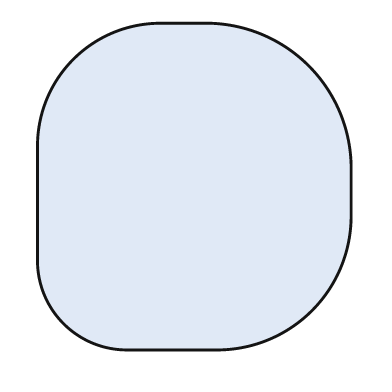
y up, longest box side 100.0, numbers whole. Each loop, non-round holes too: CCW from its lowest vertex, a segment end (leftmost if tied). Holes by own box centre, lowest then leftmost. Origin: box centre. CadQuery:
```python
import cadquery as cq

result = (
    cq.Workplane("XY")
    .moveTo(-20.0, -50.0)
    .lineTo(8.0, -50.0)
    .threePointArc((36.0, -38.0), (48.0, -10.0))
    .lineTo(48.0, 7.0)
    .threePointArc((35.0, 37.0), (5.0, 50.0))
    .lineTo(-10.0, 50.0)
    .threePointArc((-37.0, 39.0), (-48.0, 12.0))
    .lineTo(-48.0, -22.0)
    .threePointArc((-40.0, -42.0), (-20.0, -50.0))
    .close()
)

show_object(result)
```